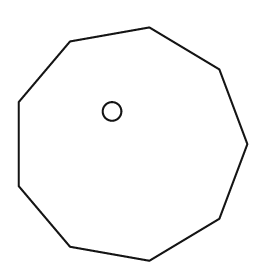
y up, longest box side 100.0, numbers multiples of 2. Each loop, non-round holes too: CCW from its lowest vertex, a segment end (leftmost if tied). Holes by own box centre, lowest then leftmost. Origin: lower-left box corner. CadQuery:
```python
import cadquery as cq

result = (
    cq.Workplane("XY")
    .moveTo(56.0, 0.0)
    .lineTo(86.0, 18.0)
    .lineTo(98.0, 50.0)
    .lineTo(86.0, 82.0)
    .lineTo(56.0, 100.0)
    .lineTo(22.0, 94.0)
    .lineTo(0.0, 68.0)
    .lineTo(0.0, 32.0)
    .lineTo(22.0, 6.0)
    .close()
    .moveTo(40.0, 64.0)
    .circle(4.0)
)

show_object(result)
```